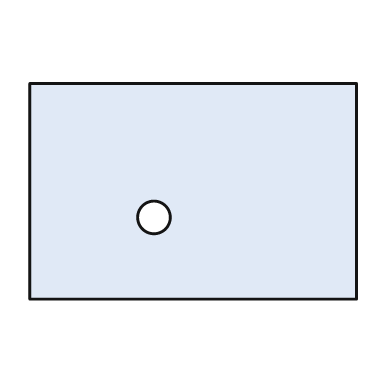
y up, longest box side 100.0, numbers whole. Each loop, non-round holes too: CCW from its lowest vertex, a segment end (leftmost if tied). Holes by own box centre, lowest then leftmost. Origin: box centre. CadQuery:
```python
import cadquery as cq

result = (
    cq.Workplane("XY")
    .moveTo(-50.0, -33.0)
    .lineTo(50.0, -33.0)
    .lineTo(50.0, 33.0)
    .lineTo(-50.0, 33.0)
    .close()
    .moveTo(-12.0, -8.0)
    .circle(5.0)
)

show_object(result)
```